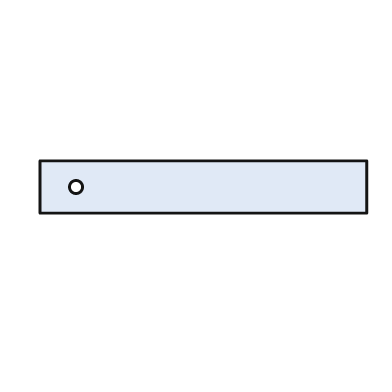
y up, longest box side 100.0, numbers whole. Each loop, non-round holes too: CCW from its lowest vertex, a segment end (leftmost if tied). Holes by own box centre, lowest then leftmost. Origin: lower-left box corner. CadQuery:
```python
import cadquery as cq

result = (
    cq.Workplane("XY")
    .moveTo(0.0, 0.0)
    .lineTo(100.0, 0.0)
    .lineTo(100.0, 16.0)
    .lineTo(0.0, 16.0)
    .close()
    .moveTo(11.0, 8.0)
    .circle(2.0)
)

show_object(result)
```